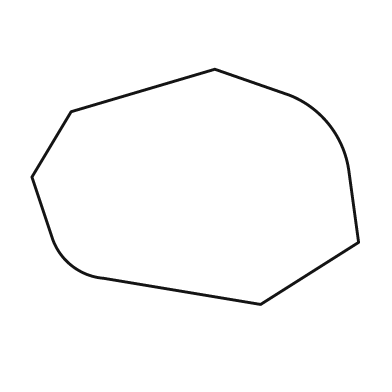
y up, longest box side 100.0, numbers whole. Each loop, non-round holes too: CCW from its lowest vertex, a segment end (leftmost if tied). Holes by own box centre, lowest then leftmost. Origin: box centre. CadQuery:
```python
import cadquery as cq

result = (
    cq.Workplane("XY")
    .moveTo(20.0, -36.0)
    .lineTo(50.0, -17.0)
    .lineTo(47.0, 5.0)
    .threePointArc((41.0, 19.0), (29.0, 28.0))
    .lineTo(6.0, 36.0)
    .lineTo(-38.0, 23.0)
    .lineTo(-50.0, 3.0)
    .lineTo(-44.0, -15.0)
    .threePointArc((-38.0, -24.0), (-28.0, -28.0))
    .close()
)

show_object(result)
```